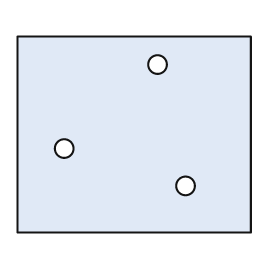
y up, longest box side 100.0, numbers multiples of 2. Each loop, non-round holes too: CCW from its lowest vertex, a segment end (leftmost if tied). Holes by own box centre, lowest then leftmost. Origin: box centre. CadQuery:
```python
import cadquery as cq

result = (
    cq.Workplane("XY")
    .moveTo(-50.0, -42.0)
    .lineTo(50.0, -42.0)
    .lineTo(50.0, 42.0)
    .lineTo(-50.0, 42.0)
    .close()
    .moveTo(22.0, -22.0)
    .circle(4.0)
    .moveTo(-30.0, -6.0)
    .circle(4.0)
    .moveTo(10.0, 30.0)
    .circle(4.0)
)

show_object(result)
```